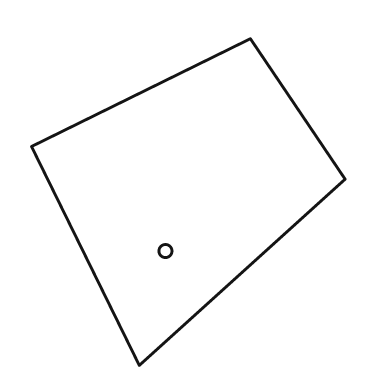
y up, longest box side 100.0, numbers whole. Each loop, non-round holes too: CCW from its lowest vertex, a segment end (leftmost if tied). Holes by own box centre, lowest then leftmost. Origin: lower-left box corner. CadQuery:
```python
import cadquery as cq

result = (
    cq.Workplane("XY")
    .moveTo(33.0, 0.0)
    .lineTo(96.0, 57.0)
    .lineTo(67.0, 100.0)
    .lineTo(0.0, 67.0)
    .close()
    .moveTo(41.0, 35.0)
    .circle(2.0)
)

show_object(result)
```